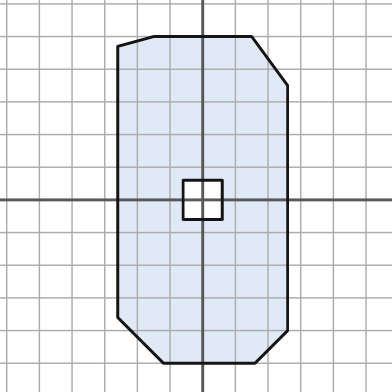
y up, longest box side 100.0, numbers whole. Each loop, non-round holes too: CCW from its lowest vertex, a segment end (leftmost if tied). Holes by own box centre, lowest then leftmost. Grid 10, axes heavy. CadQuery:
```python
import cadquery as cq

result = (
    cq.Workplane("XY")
    .moveTo(-12.0, -50.0)
    .lineTo(16.0, -50.0)
    .lineTo(26.0, -40.0)
    .lineTo(26.0, 35.0)
    .lineTo(15.0, 50.0)
    .lineTo(-15.0, 50.0)
    .lineTo(-26.0, 47.0)
    .lineTo(-26.0, -36.0)
    .close()
    .moveTo(-6.0, -6.0)
    .lineTo(6.0, -6.0)
    .lineTo(6.0, 6.0)
    .lineTo(-6.0, 6.0)
    .close()
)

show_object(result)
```